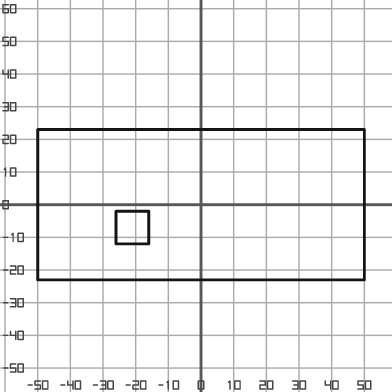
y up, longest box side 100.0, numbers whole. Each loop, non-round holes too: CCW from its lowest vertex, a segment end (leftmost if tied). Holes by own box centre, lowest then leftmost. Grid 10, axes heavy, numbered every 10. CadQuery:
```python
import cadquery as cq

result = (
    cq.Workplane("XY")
    .moveTo(-50.0, -23.0)
    .lineTo(50.0, -23.0)
    .lineTo(50.0, 23.0)
    .lineTo(-50.0, 23.0)
    .close()
    .moveTo(-26.0, -12.0)
    .lineTo(-16.0, -12.0)
    .lineTo(-16.0, -2.0)
    .lineTo(-26.0, -2.0)
    .close()
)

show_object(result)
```